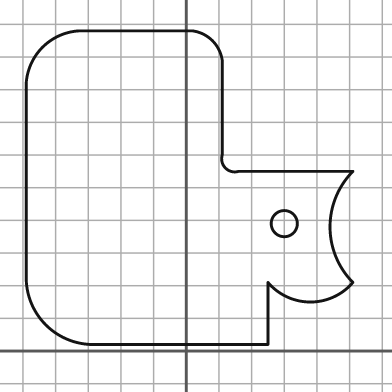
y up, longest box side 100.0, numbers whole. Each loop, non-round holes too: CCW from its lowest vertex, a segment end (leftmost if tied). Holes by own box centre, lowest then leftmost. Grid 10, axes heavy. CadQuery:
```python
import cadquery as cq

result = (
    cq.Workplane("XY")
    .moveTo(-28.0, 2.0)
    .lineTo(25.0, 2.0)
    .lineTo(25.0, 21.0)
    .threePointArc((38.0, 15.0), (51.0, 21.0))
    .threePointArc((44.0, 38.0), (51.0, 55.0))
    .lineTo(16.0, 55.0)
    .threePointArc((12.0, 56.0), (11.0, 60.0))
    .lineTo(11.0, 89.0)
    .threePointArc((8.0, 95.0), (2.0, 98.0))
    .lineTo(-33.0, 98.0)
    .threePointArc((-44.0, 93.0), (-49.0, 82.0))
    .lineTo(-49.0, 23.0)
    .threePointArc((-43.0, 8.0), (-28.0, 2.0))
    .close()
    .moveTo(30.0, 39.0)
    .circle(4.0)
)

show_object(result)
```